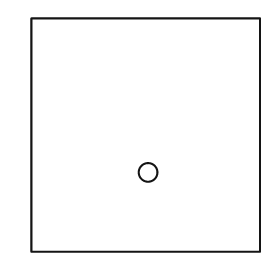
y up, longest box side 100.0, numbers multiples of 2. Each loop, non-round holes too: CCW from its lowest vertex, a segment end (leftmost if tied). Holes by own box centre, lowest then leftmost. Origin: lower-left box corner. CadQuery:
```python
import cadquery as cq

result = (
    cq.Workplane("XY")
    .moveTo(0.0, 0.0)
    .lineTo(98.0, 0.0)
    .lineTo(98.0, 100.0)
    .lineTo(0.0, 100.0)
    .close()
    .moveTo(50.0, 34.0)
    .circle(4.0)
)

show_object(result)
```